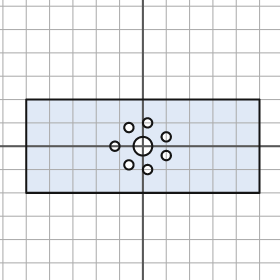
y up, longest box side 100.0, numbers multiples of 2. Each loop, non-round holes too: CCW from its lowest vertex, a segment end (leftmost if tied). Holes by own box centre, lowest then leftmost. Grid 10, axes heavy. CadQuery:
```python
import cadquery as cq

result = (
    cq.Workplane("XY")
    .moveTo(-50.0, -20.0)
    .lineTo(50.0, -20.0)
    .lineTo(50.0, 20.0)
    .lineTo(-50.0, 20.0)
    .close()
    .moveTo(2.0, -10.0)
    .circle(2.0)
    .moveTo(-6.0, -8.0)
    .circle(2.0)
    .moveTo(10.0, -4.0)
    .circle(2.0)
    .moveTo(-12.0, 0.0)
    .circle(2.0)
    .moveTo(0.0, 0.0)
    .circle(4.0)
    .moveTo(10.0, 4.0)
    .circle(2.0)
    .moveTo(-6.0, 8.0)
    .circle(2.0)
    .moveTo(2.0, 10.0)
    .circle(2.0)
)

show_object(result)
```